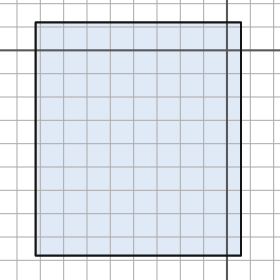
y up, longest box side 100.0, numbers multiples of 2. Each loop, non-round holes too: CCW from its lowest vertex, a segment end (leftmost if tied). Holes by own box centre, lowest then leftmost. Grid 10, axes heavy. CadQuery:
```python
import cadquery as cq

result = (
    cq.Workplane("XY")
    .moveTo(-82.0, -88.0)
    .lineTo(6.0, -88.0)
    .lineTo(6.0, 12.0)
    .lineTo(-82.0, 12.0)
    .close()
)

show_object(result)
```